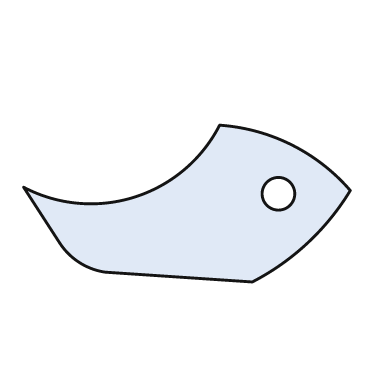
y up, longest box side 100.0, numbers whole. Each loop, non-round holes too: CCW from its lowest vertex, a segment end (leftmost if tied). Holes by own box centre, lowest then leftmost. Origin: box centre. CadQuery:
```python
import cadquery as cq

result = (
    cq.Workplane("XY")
    .moveTo(20.0, -24.0)
    .threePointArc((37.0, -12.0), (50.0, 4.0))
    .threePointArc((32.0, 18.0), (10.0, 24.0))
    .threePointArc((-16.0, 2.0), (-50.0, 5.0))
    .lineTo(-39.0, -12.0)
    .threePointArc((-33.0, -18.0), (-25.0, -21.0))
    .close()
    .moveTo(28.0, 3.0)
    .circle(5.0)
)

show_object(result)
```